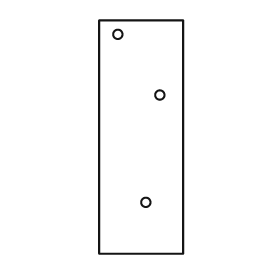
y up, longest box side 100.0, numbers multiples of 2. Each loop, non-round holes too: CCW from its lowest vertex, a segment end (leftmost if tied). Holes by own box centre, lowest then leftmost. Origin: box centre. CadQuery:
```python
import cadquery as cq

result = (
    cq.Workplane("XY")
    .moveTo(-18.0, -50.0)
    .lineTo(18.0, -50.0)
    .lineTo(18.0, 50.0)
    .lineTo(-18.0, 50.0)
    .close()
    .moveTo(2.0, -28.0)
    .circle(2.0)
    .moveTo(8.0, 18.0)
    .circle(2.0)
    .moveTo(-10.0, 44.0)
    .circle(2.0)
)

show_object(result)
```